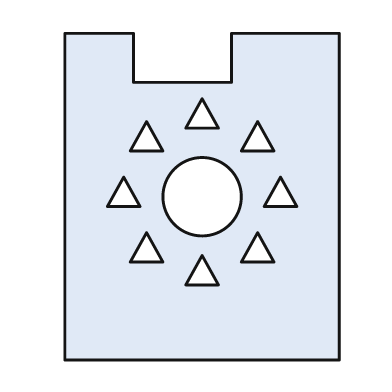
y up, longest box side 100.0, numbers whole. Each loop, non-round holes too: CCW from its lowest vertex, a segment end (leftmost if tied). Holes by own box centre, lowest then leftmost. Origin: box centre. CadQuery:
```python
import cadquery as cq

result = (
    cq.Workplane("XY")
    .moveTo(-42.0, -50.0)
    .lineTo(42.0, -50.0)
    .lineTo(42.0, 50.0)
    .lineTo(9.0, 50.0)
    .lineTo(9.0, 35.0)
    .lineTo(-21.0, 35.0)
    .lineTo(-21.0, 50.0)
    .lineTo(-42.0, 50.0)
    .close()
    .moveTo(-5.0, -27.0)
    .lineTo(5.0, -27.0)
    .lineTo(0.0, -18.0)
    .close()
    .moveTo(-22.0, -20.0)
    .lineTo(-12.0, -20.0)
    .lineTo(-17.0, -11.0)
    .close()
    .moveTo(12.0, -20.0)
    .lineTo(22.0, -20.0)
    .lineTo(17.0, -11.0)
    .close()
    .moveTo(0.0, 0.0)
    .circle(12.0)
    .moveTo(-29.0, -3.0)
    .lineTo(-19.0, -3.0)
    .lineTo(-24.0, 6.0)
    .close()
    .moveTo(19.0, -3.0)
    .lineTo(29.0, -3.0)
    .lineTo(24.0, 6.0)
    .close()
    .moveTo(-22.0, 14.0)
    .lineTo(-12.0, 14.0)
    .lineTo(-17.0, 23.0)
    .close()
    .moveTo(12.0, 14.0)
    .lineTo(22.0, 14.0)
    .lineTo(17.0, 23.0)
    .close()
    .moveTo(-5.0, 21.0)
    .lineTo(5.0, 21.0)
    .lineTo(0.0, 30.0)
    .close()
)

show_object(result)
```